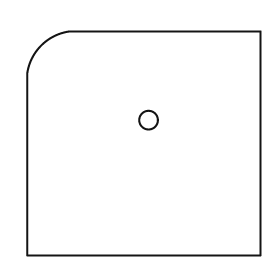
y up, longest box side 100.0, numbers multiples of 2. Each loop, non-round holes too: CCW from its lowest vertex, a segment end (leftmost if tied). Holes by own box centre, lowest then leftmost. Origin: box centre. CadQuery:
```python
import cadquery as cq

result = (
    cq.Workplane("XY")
    .moveTo(-50.0, -48.0)
    .lineTo(50.0, -48.0)
    .lineTo(50.0, 48.0)
    .lineTo(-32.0, 48.0)
    .threePointArc((-44.0, 42.0), (-50.0, 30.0))
    .close()
    .moveTo(2.0, 10.0)
    .circle(4.0)
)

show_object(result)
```